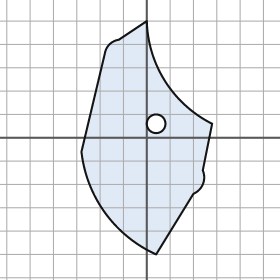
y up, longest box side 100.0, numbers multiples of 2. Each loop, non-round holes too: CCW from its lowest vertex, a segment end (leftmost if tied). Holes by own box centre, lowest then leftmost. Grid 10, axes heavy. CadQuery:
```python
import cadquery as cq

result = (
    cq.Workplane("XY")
    .moveTo(4.0, -50.0)
    .lineTo(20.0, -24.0)
    .threePointArc((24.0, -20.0), (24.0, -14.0))
    .lineTo(28.0, 6.0)
    .threePointArc((8.0, 24.0), (0.0, 50.0))
    .lineTo(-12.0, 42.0)
    .threePointArc((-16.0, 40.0), (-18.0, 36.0))
    .lineTo(-28.0, -6.0)
    .threePointArc((-18.0, -32.0), (4.0, -50.0))
    .close()
    .moveTo(4.0, 6.0)
    .circle(4.0)
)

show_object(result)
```